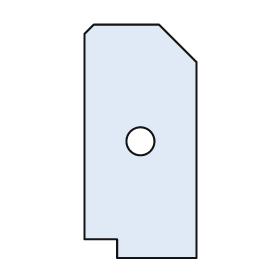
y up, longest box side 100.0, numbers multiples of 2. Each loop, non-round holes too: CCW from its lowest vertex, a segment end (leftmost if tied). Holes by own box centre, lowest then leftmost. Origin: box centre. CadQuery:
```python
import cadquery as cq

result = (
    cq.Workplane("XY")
    .moveTo(-10.0, -50.0)
    .lineTo(24.0, -50.0)
    .lineTo(24.0, 34.0)
    .lineTo(8.0, 50.0)
    .lineTo(-20.0, 50.0)
    .lineTo(-24.0, 46.0)
    .lineTo(-24.0, -42.0)
    .lineTo(-10.0, -42.0)
    .close()
    .moveTo(0.0, 0.0)
    .circle(6.0)
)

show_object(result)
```